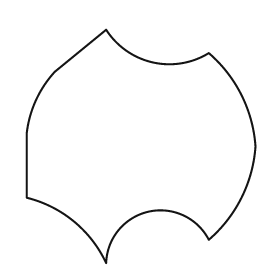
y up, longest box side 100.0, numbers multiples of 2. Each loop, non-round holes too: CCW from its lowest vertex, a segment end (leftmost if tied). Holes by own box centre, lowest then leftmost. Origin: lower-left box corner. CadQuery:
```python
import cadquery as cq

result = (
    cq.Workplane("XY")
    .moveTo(34.0, 0.0)
    .threePointArc((52.0, 22.0), (78.0, 10.0))
    .threePointArc((92.0, 28.0), (98.0, 50.0))
    .threePointArc((92.0, 72.0), (78.0, 90.0))
    .threePointArc((54.0, 86.0), (34.0, 100.0))
    .lineTo(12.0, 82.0)
    .threePointArc((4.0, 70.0), (0.0, 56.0))
    .lineTo(0.0, 28.0)
    .threePointArc((20.0, 18.0), (34.0, 0.0))
    .close()
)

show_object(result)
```